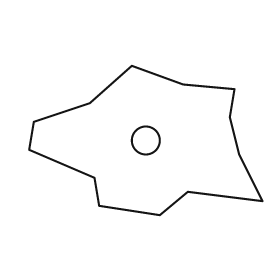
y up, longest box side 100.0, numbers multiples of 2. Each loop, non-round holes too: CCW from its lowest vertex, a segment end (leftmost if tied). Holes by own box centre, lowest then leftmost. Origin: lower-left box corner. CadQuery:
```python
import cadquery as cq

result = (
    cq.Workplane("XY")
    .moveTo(56.0, 0.0)
    .lineTo(68.0, 10.0)
    .lineTo(100.0, 6.0)
    .lineTo(90.0, 26.0)
    .lineTo(86.0, 42.0)
    .lineTo(88.0, 54.0)
    .lineTo(66.0, 56.0)
    .lineTo(44.0, 64.0)
    .lineTo(26.0, 48.0)
    .lineTo(2.0, 40.0)
    .lineTo(0.0, 28.0)
    .lineTo(28.0, 16.0)
    .lineTo(30.0, 4.0)
    .close()
    .moveTo(50.0, 32.0)
    .circle(6.0)
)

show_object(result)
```